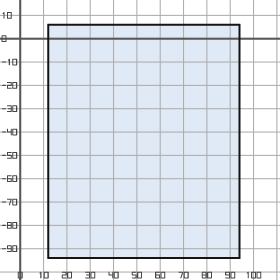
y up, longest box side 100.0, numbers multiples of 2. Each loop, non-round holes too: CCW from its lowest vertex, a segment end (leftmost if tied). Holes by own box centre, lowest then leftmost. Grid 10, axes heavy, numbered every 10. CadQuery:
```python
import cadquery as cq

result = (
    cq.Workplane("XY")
    .moveTo(12.0, -94.0)
    .lineTo(94.0, -94.0)
    .lineTo(94.0, 6.0)
    .lineTo(12.0, 6.0)
    .close()
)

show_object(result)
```